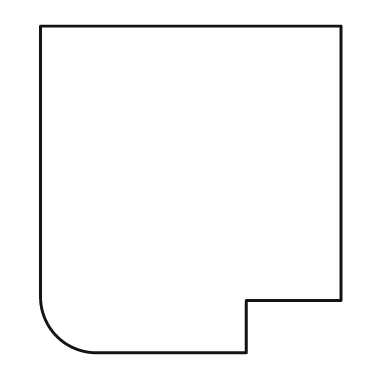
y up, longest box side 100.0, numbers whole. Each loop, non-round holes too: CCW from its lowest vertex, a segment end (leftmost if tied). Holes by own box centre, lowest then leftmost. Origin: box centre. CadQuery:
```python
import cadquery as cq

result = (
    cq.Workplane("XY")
    .moveTo(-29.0, -50.0)
    .lineTo(17.0, -50.0)
    .lineTo(17.0, -34.0)
    .lineTo(46.0, -34.0)
    .lineTo(46.0, 50.0)
    .lineTo(-46.0, 50.0)
    .lineTo(-46.0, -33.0)
    .threePointArc((-41.0, -45.0), (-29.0, -50.0))
    .close()
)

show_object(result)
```